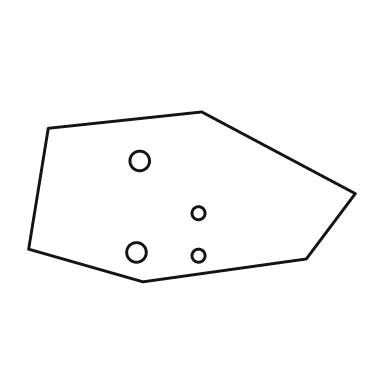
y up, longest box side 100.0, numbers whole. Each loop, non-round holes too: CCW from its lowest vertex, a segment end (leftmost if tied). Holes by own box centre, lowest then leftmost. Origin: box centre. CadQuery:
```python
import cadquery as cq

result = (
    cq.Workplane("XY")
    .moveTo(-15.0, -26.0)
    .lineTo(35.0, -19.0)
    .lineTo(50.0, 1.0)
    .lineTo(3.0, 26.0)
    .lineTo(-44.0, 21.0)
    .lineTo(-50.0, -16.0)
    .close()
    .moveTo(2.0, -18.0)
    .circle(2.0)
    .moveTo(-17.0, -17.0)
    .circle(3.0)
    .moveTo(2.0, -5.0)
    .circle(2.0)
    .moveTo(-16.0, 11.0)
    .circle(3.0)
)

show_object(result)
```